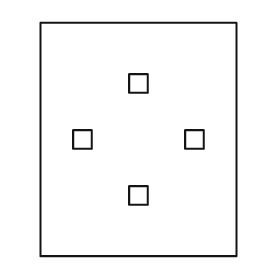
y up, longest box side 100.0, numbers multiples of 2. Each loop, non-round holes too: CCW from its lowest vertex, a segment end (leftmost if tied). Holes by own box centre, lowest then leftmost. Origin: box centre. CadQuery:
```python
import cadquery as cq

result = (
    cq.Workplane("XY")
    .moveTo(-42.0, -50.0)
    .lineTo(42.0, -50.0)
    .lineTo(42.0, 50.0)
    .lineTo(-42.0, 50.0)
    .close()
    .moveTo(-4.0, -28.0)
    .lineTo(4.0, -28.0)
    .lineTo(4.0, -20.0)
    .lineTo(-4.0, -20.0)
    .close()
    .moveTo(-28.0, -4.0)
    .lineTo(-20.0, -4.0)
    .lineTo(-20.0, 4.0)
    .lineTo(-28.0, 4.0)
    .close()
    .moveTo(20.0, -4.0)
    .lineTo(28.0, -4.0)
    .lineTo(28.0, 4.0)
    .lineTo(20.0, 4.0)
    .close()
    .moveTo(-4.0, 20.0)
    .lineTo(4.0, 20.0)
    .lineTo(4.0, 28.0)
    .lineTo(-4.0, 28.0)
    .close()
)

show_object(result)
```